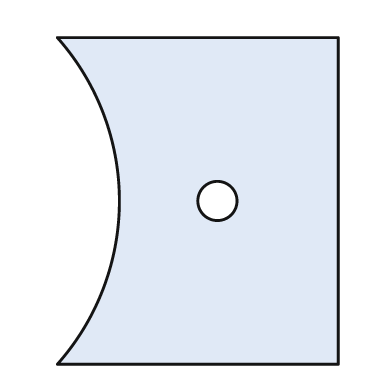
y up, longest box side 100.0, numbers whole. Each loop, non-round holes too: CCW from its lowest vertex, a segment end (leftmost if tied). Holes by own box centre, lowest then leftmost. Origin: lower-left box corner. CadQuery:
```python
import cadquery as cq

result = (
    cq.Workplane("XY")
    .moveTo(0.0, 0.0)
    .lineTo(86.0, 0.0)
    .lineTo(86.0, 100.0)
    .lineTo(0.0, 100.0)
    .threePointArc((19.0, 50.0), (0.0, 0.0))
    .close()
    .moveTo(49.0, 50.0)
    .circle(6.0)
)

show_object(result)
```